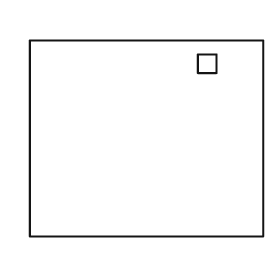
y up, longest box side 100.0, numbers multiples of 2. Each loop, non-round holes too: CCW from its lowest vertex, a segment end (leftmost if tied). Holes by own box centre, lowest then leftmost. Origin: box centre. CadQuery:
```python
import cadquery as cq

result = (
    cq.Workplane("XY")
    .moveTo(-50.0, -42.0)
    .lineTo(50.0, -42.0)
    .lineTo(50.0, 42.0)
    .lineTo(-50.0, 42.0)
    .close()
    .moveTo(22.0, 28.0)
    .lineTo(30.0, 28.0)
    .lineTo(30.0, 36.0)
    .lineTo(22.0, 36.0)
    .close()
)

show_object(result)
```